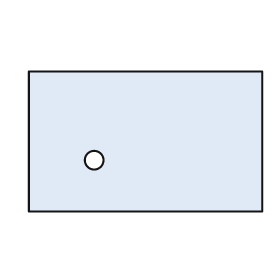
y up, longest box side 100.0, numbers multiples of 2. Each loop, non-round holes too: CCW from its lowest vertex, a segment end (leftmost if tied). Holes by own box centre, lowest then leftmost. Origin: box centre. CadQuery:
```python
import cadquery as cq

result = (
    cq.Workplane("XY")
    .moveTo(-50.0, -30.0)
    .lineTo(50.0, -30.0)
    .lineTo(50.0, 30.0)
    .lineTo(-50.0, 30.0)
    .close()
    .moveTo(-22.0, -8.0)
    .circle(4.0)
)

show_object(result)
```